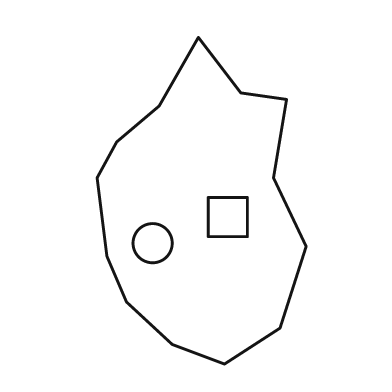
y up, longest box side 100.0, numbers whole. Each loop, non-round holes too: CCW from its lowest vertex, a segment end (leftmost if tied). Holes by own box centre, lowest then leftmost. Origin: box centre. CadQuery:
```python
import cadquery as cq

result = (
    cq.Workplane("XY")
    .moveTo(7.0, -50.0)
    .lineTo(24.0, -39.0)
    .lineTo(32.0, -14.0)
    .lineTo(22.0, 7.0)
    .lineTo(26.0, 31.0)
    .lineTo(12.0, 33.0)
    .lineTo(-1.0, 50.0)
    .lineTo(-13.0, 29.0)
    .lineTo(-26.0, 18.0)
    .lineTo(-32.0, 7.0)
    .lineTo(-29.0, -17.0)
    .lineTo(-23.0, -31.0)
    .lineTo(-9.0, -44.0)
    .close()
    .moveTo(-15.0, -13.0)
    .circle(6.0)
    .moveTo(2.0, -11.0)
    .lineTo(14.0, -11.0)
    .lineTo(14.0, 1.0)
    .lineTo(2.0, 1.0)
    .close()
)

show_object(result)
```